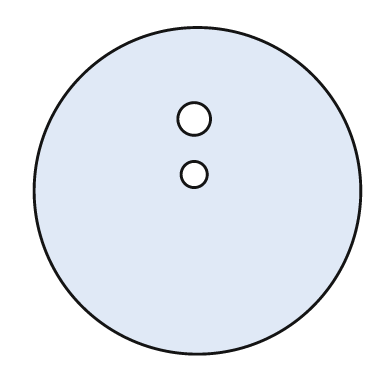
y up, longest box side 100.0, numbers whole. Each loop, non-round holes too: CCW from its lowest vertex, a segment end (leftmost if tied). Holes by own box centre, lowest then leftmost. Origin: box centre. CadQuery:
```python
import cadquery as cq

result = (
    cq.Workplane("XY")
    .moveTo(0.0, 0.0)
    .circle(50.0)
    .moveTo(-1.0, 5.0)
    .circle(4.0)
    .moveTo(-1.0, 22.0)
    .circle(5.0)
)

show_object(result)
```